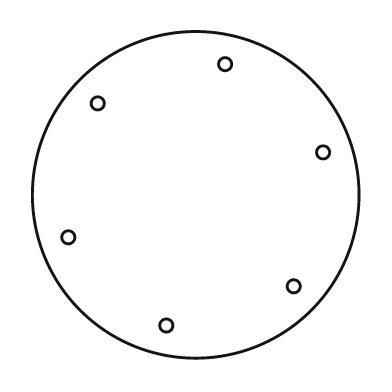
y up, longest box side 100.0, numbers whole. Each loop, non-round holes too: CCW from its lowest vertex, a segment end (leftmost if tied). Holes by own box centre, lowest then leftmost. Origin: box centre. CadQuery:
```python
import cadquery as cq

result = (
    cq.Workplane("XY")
    .moveTo(0.0, 0.0)
    .circle(50.0)
    .moveTo(-9.0, -40.0)
    .circle(2.0)
    .moveTo(30.0, -28.0)
    .circle(2.0)
    .moveTo(-39.0, -13.0)
    .circle(2.0)
    .moveTo(39.0, 13.0)
    .circle(2.0)
    .moveTo(-30.0, 28.0)
    .circle(2.0)
    .moveTo(9.0, 40.0)
    .circle(2.0)
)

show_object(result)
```